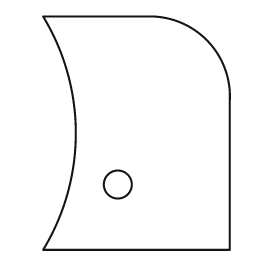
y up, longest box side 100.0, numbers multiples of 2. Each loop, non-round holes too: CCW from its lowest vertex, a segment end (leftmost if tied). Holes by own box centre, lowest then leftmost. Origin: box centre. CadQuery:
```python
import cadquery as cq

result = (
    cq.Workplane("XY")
    .moveTo(-40.0, -50.0)
    .lineTo(40.0, -50.0)
    .lineTo(40.0, 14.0)
    .threePointArc((30.0, 40.0), (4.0, 50.0))
    .lineTo(-40.0, 50.0)
    .threePointArc((-26.0, 0.0), (-40.0, -50.0))
    .close()
    .moveTo(-8.0, -22.0)
    .circle(6.0)
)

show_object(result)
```